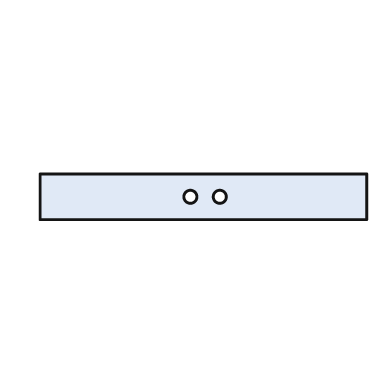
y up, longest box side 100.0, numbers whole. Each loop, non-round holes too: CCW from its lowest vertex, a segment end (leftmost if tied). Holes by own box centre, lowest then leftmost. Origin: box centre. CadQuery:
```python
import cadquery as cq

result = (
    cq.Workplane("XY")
    .moveTo(-50.0, -7.0)
    .lineTo(50.0, -7.0)
    .lineTo(50.0, 7.0)
    .lineTo(-50.0, 7.0)
    .close()
    .moveTo(-4.0, 0.0)
    .circle(2.0)
    .moveTo(5.0, 0.0)
    .circle(2.0)
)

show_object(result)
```